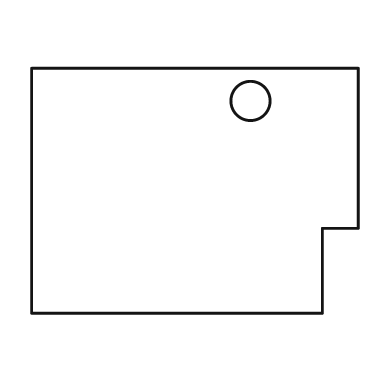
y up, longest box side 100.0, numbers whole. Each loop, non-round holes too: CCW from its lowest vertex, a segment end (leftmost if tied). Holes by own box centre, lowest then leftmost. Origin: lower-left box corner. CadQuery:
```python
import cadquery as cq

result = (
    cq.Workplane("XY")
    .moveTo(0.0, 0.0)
    .lineTo(89.0, 0.0)
    .lineTo(89.0, 26.0)
    .lineTo(100.0, 26.0)
    .lineTo(100.0, 75.0)
    .lineTo(0.0, 75.0)
    .close()
    .moveTo(67.0, 65.0)
    .circle(6.0)
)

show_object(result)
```